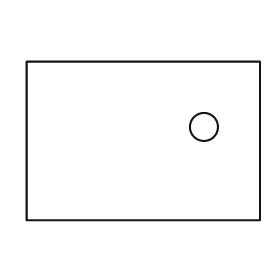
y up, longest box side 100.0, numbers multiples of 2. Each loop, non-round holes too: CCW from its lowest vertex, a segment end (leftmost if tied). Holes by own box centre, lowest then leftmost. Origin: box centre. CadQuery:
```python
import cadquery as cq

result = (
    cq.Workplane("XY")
    .moveTo(-50.0, -34.0)
    .lineTo(50.0, -34.0)
    .lineTo(50.0, 34.0)
    .lineTo(-50.0, 34.0)
    .close()
    .moveTo(26.0, 6.0)
    .circle(6.0)
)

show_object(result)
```